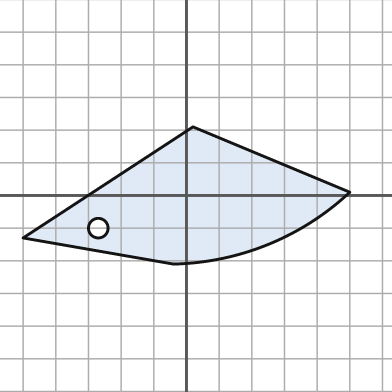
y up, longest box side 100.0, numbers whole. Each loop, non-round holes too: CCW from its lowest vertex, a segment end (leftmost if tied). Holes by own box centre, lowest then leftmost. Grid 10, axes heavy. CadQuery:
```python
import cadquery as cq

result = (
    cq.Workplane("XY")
    .moveTo(-4.0, -21.0)
    .threePointArc((25.0, -15.0), (50.0, 1.0))
    .lineTo(2.0, 21.0)
    .lineTo(-50.0, -13.0)
    .close()
    .moveTo(-27.0, -10.0)
    .circle(3.0)
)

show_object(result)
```